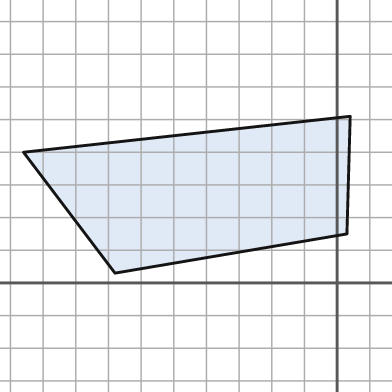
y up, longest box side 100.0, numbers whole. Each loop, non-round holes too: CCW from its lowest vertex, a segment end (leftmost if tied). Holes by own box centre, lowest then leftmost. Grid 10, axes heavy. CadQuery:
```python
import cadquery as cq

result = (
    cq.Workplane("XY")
    .moveTo(-68.0, 3.0)
    .lineTo(3.0, 15.0)
    .lineTo(4.0, 51.0)
    .lineTo(-96.0, 40.0)
    .close()
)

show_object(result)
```